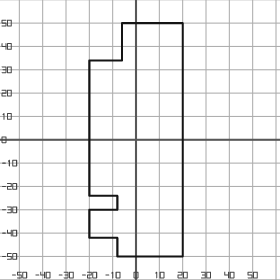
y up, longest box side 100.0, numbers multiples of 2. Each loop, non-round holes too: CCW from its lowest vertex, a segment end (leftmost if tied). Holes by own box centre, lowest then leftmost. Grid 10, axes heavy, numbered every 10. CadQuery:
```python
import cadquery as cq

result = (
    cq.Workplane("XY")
    .moveTo(-8.0, -50.0)
    .lineTo(20.0, -50.0)
    .lineTo(20.0, 50.0)
    .lineTo(-6.0, 50.0)
    .lineTo(-6.0, 34.0)
    .lineTo(-20.0, 34.0)
    .lineTo(-20.0, -24.0)
    .lineTo(-8.0, -24.0)
    .lineTo(-8.0, -30.0)
    .lineTo(-20.0, -30.0)
    .lineTo(-20.0, -42.0)
    .lineTo(-8.0, -42.0)
    .close()
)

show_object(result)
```